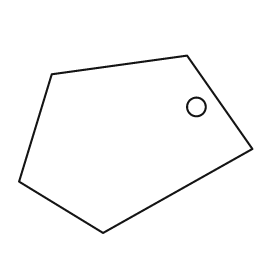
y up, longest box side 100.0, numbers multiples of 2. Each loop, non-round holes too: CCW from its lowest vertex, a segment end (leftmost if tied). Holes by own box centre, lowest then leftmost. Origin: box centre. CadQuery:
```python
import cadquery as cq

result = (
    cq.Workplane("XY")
    .moveTo(-14.0, -38.0)
    .lineTo(50.0, -2.0)
    .lineTo(22.0, 38.0)
    .lineTo(-36.0, 30.0)
    .lineTo(-50.0, -16.0)
    .close()
    .moveTo(26.0, 16.0)
    .circle(4.0)
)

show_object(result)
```